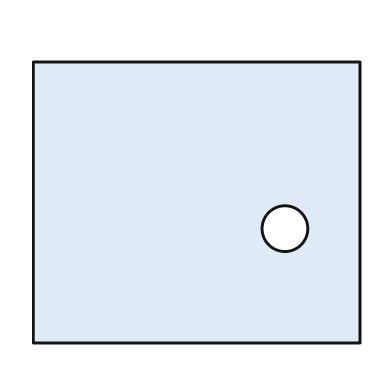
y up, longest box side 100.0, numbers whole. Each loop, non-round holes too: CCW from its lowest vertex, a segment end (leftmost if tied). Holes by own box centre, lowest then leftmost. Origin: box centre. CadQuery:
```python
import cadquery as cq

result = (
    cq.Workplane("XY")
    .moveTo(-50.0, -43.0)
    .lineTo(50.0, -43.0)
    .lineTo(50.0, 43.0)
    .lineTo(-50.0, 43.0)
    .close()
    .moveTo(27.0, -8.0)
    .circle(7.0)
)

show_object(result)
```